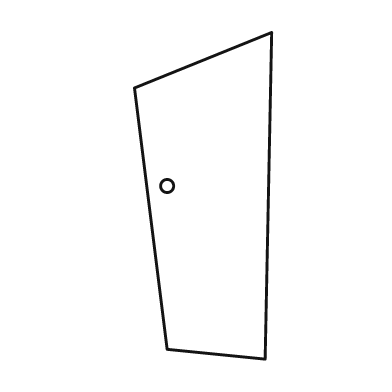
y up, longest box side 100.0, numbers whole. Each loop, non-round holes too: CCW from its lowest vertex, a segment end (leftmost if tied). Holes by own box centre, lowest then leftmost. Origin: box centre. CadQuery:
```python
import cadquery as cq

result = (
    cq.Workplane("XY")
    .moveTo(19.0, -50.0)
    .lineTo(21.0, 50.0)
    .lineTo(-21.0, 33.0)
    .lineTo(-11.0, -47.0)
    .close()
    .moveTo(-11.0, 3.0)
    .circle(2.0)
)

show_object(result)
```